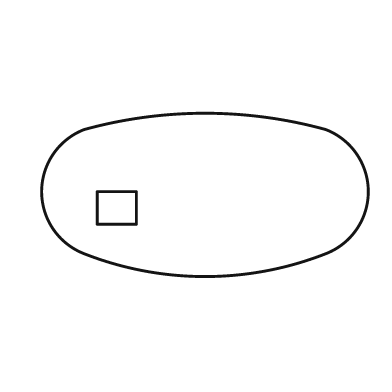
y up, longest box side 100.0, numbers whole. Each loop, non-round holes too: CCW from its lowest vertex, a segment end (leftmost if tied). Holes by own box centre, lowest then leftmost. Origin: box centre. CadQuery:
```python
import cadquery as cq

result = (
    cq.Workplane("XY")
    .moveTo(-37.0, -18.0)
    .threePointArc((0.0, -25.0), (37.0, -18.0))
    .threePointArc((50.0, 1.0), (37.0, 20.0))
    .threePointArc((0.0, 25.0), (-37.0, 20.0))
    .threePointArc((-50.0, 1.0), (-37.0, -18.0))
    .close()
    .moveTo(-33.0, -9.0)
    .lineTo(-21.0, -9.0)
    .lineTo(-21.0, 1.0)
    .lineTo(-33.0, 1.0)
    .close()
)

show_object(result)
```